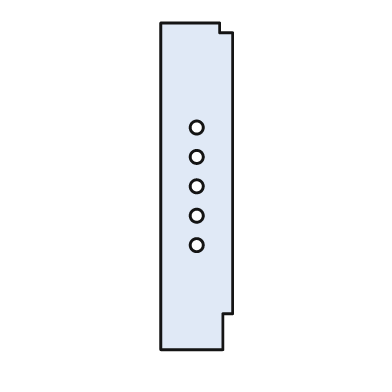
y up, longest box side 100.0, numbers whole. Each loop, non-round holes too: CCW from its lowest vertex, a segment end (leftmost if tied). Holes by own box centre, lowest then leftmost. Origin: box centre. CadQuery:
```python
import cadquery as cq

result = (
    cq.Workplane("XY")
    .moveTo(-11.0, -50.0)
    .lineTo(8.0, -50.0)
    .lineTo(8.0, -39.0)
    .lineTo(11.0, -39.0)
    .lineTo(11.0, 47.0)
    .lineTo(7.0, 47.0)
    .lineTo(7.0, 50.0)
    .lineTo(-11.0, 50.0)
    .close()
    .moveTo(0.0, -18.0)
    .circle(2.0)
    .moveTo(0.0, -9.0)
    .circle(2.0)
    .moveTo(0.0, 0.0)
    .circle(2.0)
    .moveTo(0.0, 9.0)
    .circle(2.0)
    .moveTo(0.0, 18.0)
    .circle(2.0)
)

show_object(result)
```